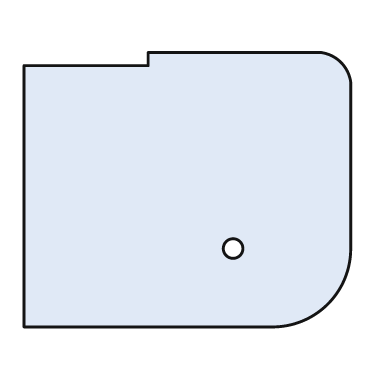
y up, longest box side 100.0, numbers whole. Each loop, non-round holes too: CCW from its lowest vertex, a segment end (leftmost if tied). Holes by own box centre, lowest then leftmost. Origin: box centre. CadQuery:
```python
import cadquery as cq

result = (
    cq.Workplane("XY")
    .moveTo(-50.0, -42.0)
    .lineTo(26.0, -42.0)
    .threePointArc((43.0, -35.0), (50.0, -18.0))
    .lineTo(50.0, 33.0)
    .threePointArc((47.0, 39.0), (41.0, 42.0))
    .lineTo(-12.0, 42.0)
    .lineTo(-12.0, 38.0)
    .lineTo(-50.0, 38.0)
    .close()
    .moveTo(14.0, -18.0)
    .circle(3.0)
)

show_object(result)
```